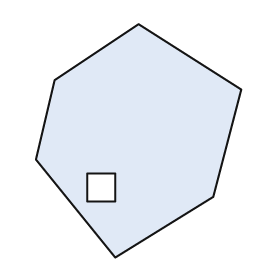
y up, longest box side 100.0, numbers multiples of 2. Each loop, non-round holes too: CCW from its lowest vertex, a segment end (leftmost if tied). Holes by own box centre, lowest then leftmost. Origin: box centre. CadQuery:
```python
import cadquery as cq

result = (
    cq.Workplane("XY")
    .moveTo(-10.0, -50.0)
    .lineTo(32.0, -24.0)
    .lineTo(44.0, 22.0)
    .lineTo(0.0, 50.0)
    .lineTo(-36.0, 26.0)
    .lineTo(-44.0, -8.0)
    .close()
    .moveTo(-22.0, -26.0)
    .lineTo(-10.0, -26.0)
    .lineTo(-10.0, -14.0)
    .lineTo(-22.0, -14.0)
    .close()
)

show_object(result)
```